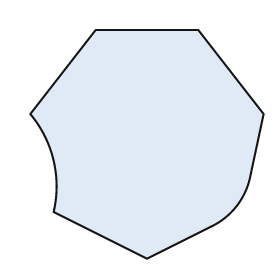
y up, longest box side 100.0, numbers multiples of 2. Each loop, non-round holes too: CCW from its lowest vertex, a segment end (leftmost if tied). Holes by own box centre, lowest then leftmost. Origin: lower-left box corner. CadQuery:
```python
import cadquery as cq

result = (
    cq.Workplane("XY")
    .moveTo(50.0, 0.0)
    .lineTo(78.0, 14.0)
    .threePointArc((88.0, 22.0), (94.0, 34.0))
    .lineTo(100.0, 62.0)
    .lineTo(72.0, 98.0)
    .lineTo(28.0, 98.0)
    .lineTo(0.0, 62.0)
    .threePointArc((10.0, 42.0), (10.0, 20.0))
    .close()
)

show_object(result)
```